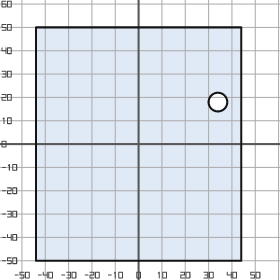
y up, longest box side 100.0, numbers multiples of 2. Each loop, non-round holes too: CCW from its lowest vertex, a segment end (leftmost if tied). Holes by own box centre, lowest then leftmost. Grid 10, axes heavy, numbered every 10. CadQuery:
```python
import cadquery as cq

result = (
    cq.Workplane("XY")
    .moveTo(-44.0, -50.0)
    .lineTo(44.0, -50.0)
    .lineTo(44.0, 50.0)
    .lineTo(-44.0, 50.0)
    .close()
    .moveTo(34.0, 18.0)
    .circle(4.0)
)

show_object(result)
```